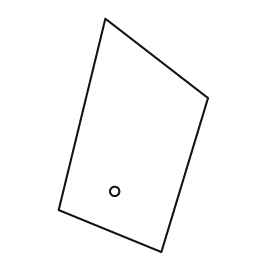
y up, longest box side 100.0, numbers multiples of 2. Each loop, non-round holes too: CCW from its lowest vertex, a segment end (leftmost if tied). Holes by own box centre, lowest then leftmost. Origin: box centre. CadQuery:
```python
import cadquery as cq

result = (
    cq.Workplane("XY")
    .moveTo(12.0, -50.0)
    .lineTo(32.0, 16.0)
    .lineTo(-12.0, 50.0)
    .lineTo(-32.0, -32.0)
    .close()
    .moveTo(-8.0, -24.0)
    .circle(2.0)
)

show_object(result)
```